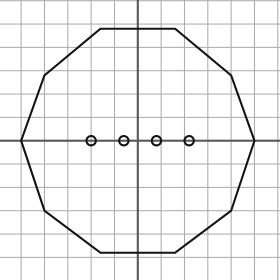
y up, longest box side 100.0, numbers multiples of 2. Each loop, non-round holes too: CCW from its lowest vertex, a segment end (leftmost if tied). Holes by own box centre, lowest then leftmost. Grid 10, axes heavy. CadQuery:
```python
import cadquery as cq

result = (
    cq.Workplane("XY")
    .moveTo(-16.0, -48.0)
    .lineTo(16.0, -48.0)
    .lineTo(40.0, -30.0)
    .lineTo(50.0, 0.0)
    .lineTo(40.0, 28.0)
    .lineTo(16.0, 48.0)
    .lineTo(-16.0, 48.0)
    .lineTo(-40.0, 28.0)
    .lineTo(-50.0, 0.0)
    .lineTo(-40.0, -30.0)
    .close()
    .moveTo(-20.0, 0.0)
    .circle(2.0)
    .moveTo(-6.0, 0.0)
    .circle(2.0)
    .moveTo(8.0, 0.0)
    .circle(2.0)
    .moveTo(22.0, 0.0)
    .circle(2.0)
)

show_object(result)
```